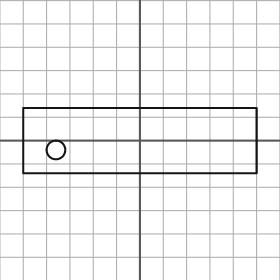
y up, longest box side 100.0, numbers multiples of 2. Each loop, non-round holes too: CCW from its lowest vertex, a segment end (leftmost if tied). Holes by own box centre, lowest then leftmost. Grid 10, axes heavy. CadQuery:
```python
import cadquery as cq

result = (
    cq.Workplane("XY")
    .moveTo(-50.0, -14.0)
    .lineTo(50.0, -14.0)
    .lineTo(50.0, 14.0)
    .lineTo(-50.0, 14.0)
    .close()
    .moveTo(-36.0, -4.0)
    .circle(4.0)
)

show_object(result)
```